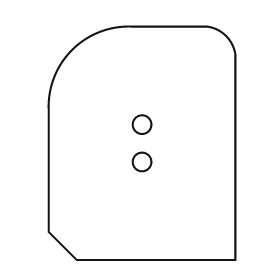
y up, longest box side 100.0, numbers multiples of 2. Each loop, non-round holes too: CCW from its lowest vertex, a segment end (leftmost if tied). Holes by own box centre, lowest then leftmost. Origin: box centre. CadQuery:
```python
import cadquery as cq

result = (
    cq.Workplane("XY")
    .moveTo(-28.0, -50.0)
    .lineTo(40.0, -50.0)
    .lineTo(40.0, 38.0)
    .threePointArc((36.0, 46.0), (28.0, 50.0))
    .lineTo(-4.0, 50.0)
    .threePointArc((-30.0, 40.0), (-40.0, 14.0))
    .lineTo(-40.0, -38.0)
    .close()
    .moveTo(0.0, -8.0)
    .circle(4.0)
    .moveTo(0.0, 8.0)
    .circle(4.0)
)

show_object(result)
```